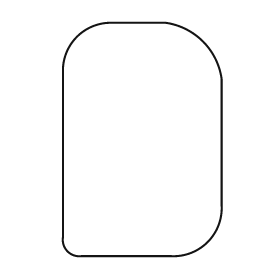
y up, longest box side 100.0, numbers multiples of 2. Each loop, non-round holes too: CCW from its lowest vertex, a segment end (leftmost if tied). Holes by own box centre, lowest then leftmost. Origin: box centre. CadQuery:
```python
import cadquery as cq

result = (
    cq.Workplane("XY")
    .moveTo(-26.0, -50.0)
    .lineTo(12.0, -50.0)
    .threePointArc((28.0, -44.0), (34.0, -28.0))
    .lineTo(34.0, 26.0)
    .threePointArc((26.0, 42.0), (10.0, 50.0))
    .lineTo(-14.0, 50.0)
    .threePointArc((-28.0, 44.0), (-34.0, 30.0))
    .lineTo(-34.0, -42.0)
    .threePointArc((-32.0, -48.0), (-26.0, -50.0))
    .close()
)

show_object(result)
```